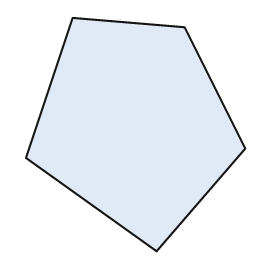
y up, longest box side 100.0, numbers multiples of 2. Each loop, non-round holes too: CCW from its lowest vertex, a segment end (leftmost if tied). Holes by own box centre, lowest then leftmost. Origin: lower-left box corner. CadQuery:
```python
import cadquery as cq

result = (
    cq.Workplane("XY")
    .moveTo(56.0, 0.0)
    .lineTo(94.0, 44.0)
    .lineTo(68.0, 96.0)
    .lineTo(20.0, 100.0)
    .lineTo(0.0, 40.0)
    .close()
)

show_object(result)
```